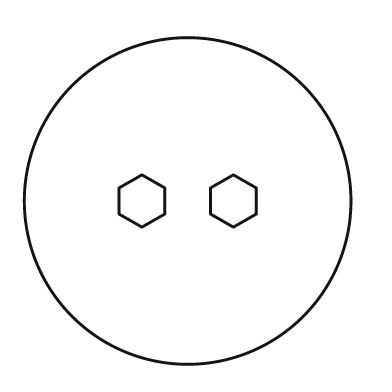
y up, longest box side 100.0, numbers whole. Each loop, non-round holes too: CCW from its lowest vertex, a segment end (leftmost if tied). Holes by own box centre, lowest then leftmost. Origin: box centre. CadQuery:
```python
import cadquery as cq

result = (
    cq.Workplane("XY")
    .moveTo(0.0, 0.0)
    .circle(50.0)
    .moveTo(-14.0, -8.0)
    .lineTo(-7.0, -4.0)
    .lineTo(-7.0, 4.0)
    .lineTo(-14.0, 8.0)
    .lineTo(-21.0, 4.0)
    .lineTo(-21.0, -4.0)
    .close()
    .moveTo(14.0, -8.0)
    .lineTo(21.0, -4.0)
    .lineTo(21.0, 4.0)
    .lineTo(14.0, 8.0)
    .lineTo(7.0, 4.0)
    .lineTo(7.0, -4.0)
    .close()
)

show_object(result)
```